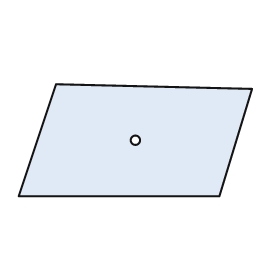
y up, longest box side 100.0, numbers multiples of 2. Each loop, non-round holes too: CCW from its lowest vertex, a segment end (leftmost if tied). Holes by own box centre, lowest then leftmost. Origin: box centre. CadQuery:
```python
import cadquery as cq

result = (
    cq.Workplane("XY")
    .moveTo(-50.0, -24.0)
    .lineTo(36.0, -24.0)
    .lineTo(50.0, 22.0)
    .lineTo(-34.0, 24.0)
    .close()
    .moveTo(0.0, 0.0)
    .circle(2.0)
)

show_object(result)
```